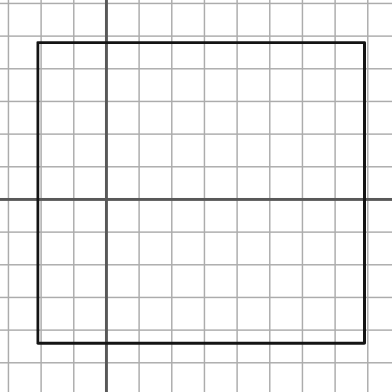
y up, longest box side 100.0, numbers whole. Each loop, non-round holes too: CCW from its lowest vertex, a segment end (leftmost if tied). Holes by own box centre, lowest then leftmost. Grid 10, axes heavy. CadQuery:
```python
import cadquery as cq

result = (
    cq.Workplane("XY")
    .moveTo(-21.0, -44.0)
    .lineTo(79.0, -44.0)
    .lineTo(79.0, 48.0)
    .lineTo(-21.0, 48.0)
    .close()
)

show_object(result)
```